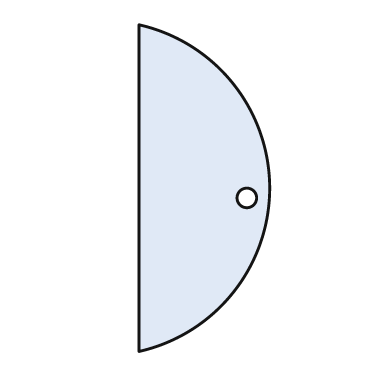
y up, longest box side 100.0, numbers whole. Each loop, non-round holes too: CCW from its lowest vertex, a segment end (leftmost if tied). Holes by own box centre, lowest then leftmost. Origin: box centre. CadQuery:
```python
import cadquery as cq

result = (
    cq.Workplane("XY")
    .moveTo(-20.0, -50.0)
    .threePointArc((20.0, 0.0), (-20.0, 50.0))
    .close()
    .moveTo(13.0, -3.0)
    .circle(3.0)
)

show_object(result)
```